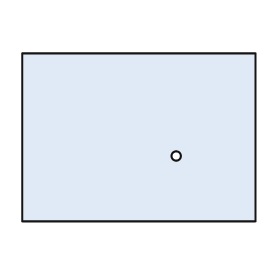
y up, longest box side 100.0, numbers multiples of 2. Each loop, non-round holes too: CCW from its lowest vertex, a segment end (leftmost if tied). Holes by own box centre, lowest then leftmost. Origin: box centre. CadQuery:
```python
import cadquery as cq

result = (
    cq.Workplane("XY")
    .moveTo(-50.0, -36.0)
    .lineTo(50.0, -36.0)
    .lineTo(50.0, 36.0)
    .lineTo(-50.0, 36.0)
    .close()
    .moveTo(16.0, -8.0)
    .circle(2.0)
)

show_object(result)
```